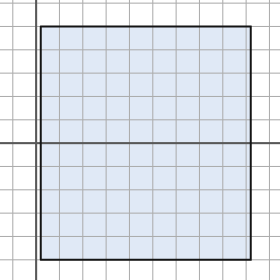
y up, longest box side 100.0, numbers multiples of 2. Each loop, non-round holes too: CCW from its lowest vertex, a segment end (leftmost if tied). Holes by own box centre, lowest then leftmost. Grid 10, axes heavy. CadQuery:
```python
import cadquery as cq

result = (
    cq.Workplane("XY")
    .moveTo(2.0, -50.0)
    .lineTo(92.0, -50.0)
    .lineTo(92.0, 50.0)
    .lineTo(2.0, 50.0)
    .close()
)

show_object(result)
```